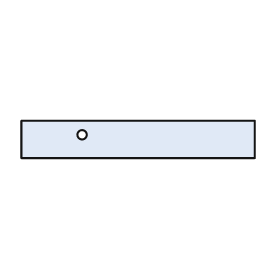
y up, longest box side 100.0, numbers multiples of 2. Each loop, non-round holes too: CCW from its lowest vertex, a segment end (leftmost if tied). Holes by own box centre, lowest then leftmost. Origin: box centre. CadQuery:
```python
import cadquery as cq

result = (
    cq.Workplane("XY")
    .moveTo(-50.0, -8.0)
    .lineTo(50.0, -8.0)
    .lineTo(50.0, 8.0)
    .lineTo(-50.0, 8.0)
    .close()
    .moveTo(-24.0, 2.0)
    .circle(2.0)
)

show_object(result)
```